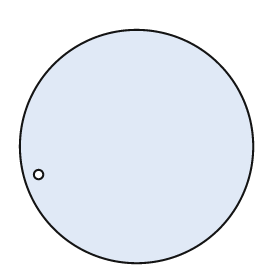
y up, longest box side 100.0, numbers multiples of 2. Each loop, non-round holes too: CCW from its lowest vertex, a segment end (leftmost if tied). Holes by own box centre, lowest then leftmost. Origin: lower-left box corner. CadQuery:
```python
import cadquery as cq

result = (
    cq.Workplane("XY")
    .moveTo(50.0, 50.0)
    .circle(50.0)
    .moveTo(8.0, 38.0)
    .circle(2.0)
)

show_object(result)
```